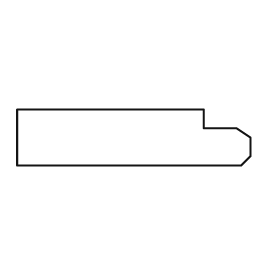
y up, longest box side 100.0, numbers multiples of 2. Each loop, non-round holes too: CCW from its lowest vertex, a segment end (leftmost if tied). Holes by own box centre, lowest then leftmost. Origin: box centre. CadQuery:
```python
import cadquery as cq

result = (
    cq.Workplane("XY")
    .moveTo(-50.0, -12.0)
    .lineTo(46.0, -12.0)
    .lineTo(50.0, -8.0)
    .lineTo(50.0, 0.0)
    .lineTo(44.0, 4.0)
    .lineTo(30.0, 4.0)
    .lineTo(30.0, 12.0)
    .lineTo(-50.0, 12.0)
    .close()
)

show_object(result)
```